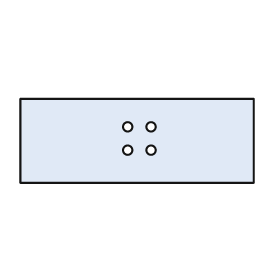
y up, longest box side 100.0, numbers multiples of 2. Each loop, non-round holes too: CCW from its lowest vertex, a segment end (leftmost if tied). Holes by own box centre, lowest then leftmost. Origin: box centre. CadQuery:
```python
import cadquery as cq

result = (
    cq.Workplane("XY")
    .moveTo(-50.0, -18.0)
    .lineTo(50.0, -18.0)
    .lineTo(50.0, 18.0)
    .lineTo(-50.0, 18.0)
    .close()
    .moveTo(-4.0, -4.0)
    .circle(2.0)
    .moveTo(6.0, -4.0)
    .circle(2.0)
    .moveTo(-4.0, 6.0)
    .circle(2.0)
    .moveTo(6.0, 6.0)
    .circle(2.0)
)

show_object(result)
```